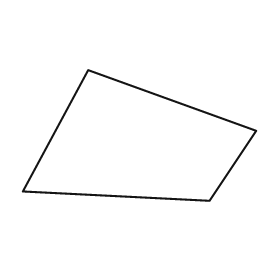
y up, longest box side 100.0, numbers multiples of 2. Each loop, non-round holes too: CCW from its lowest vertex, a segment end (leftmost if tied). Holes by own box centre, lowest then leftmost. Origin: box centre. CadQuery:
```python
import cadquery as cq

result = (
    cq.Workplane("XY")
    .moveTo(30.0, -28.0)
    .lineTo(50.0, 2.0)
    .lineTo(-22.0, 28.0)
    .lineTo(-50.0, -24.0)
    .close()
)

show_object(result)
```